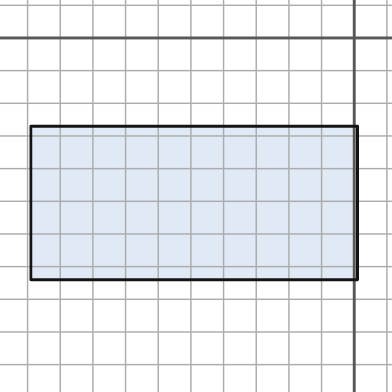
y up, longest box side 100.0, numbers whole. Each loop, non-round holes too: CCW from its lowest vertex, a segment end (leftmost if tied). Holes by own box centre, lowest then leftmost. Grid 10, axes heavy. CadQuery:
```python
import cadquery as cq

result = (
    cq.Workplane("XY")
    .moveTo(-99.0, -74.0)
    .lineTo(1.0, -74.0)
    .lineTo(1.0, -27.0)
    .lineTo(-99.0, -27.0)
    .close()
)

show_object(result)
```